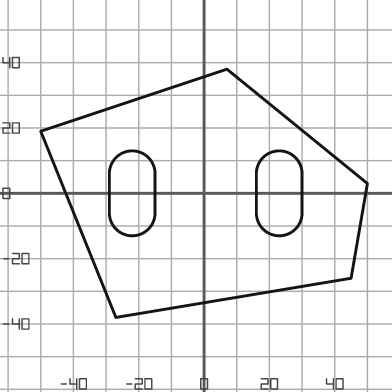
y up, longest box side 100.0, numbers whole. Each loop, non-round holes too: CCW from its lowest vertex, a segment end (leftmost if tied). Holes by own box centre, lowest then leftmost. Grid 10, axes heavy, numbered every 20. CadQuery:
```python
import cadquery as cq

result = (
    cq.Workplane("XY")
    .moveTo(-27.0, -38.0)
    .lineTo(45.0, -26.0)
    .lineTo(50.0, 3.0)
    .lineTo(7.0, 38.0)
    .lineTo(-50.0, 19.0)
    .close()
    .moveTo(-29.0, -6.0)
    .threePointArc((-22.0, -13.0), (-15.0, -6.0))
    .lineTo(-15.0, 6.0)
    .threePointArc((-22.0, 13.0), (-29.0, 6.0))
    .close()
    .moveTo(16.0, -6.0)
    .threePointArc((23.0, -13.0), (30.0, -6.0))
    .lineTo(30.0, 6.0)
    .threePointArc((23.0, 13.0), (16.0, 6.0))
    .close()
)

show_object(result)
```